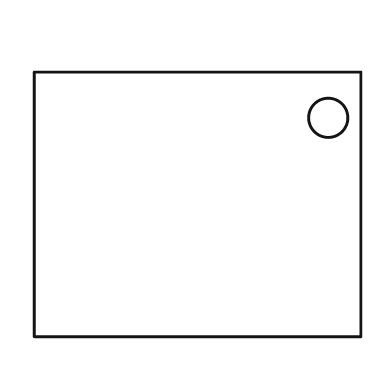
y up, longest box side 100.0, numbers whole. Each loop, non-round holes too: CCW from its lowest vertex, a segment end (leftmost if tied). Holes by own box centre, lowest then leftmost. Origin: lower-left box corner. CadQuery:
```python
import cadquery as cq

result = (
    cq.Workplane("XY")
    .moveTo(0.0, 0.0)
    .lineTo(100.0, 0.0)
    .lineTo(100.0, 81.0)
    .lineTo(0.0, 81.0)
    .close()
    .moveTo(90.0, 67.0)
    .circle(6.0)
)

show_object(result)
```